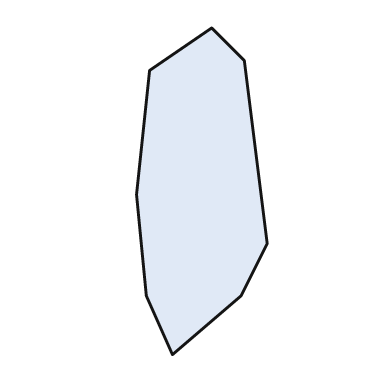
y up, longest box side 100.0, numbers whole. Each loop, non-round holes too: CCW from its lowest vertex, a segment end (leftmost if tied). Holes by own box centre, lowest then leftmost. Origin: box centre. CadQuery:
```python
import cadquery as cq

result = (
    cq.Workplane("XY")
    .moveTo(-9.0, -50.0)
    .lineTo(12.0, -32.0)
    .lineTo(20.0, -16.0)
    .lineTo(13.0, 40.0)
    .lineTo(3.0, 50.0)
    .lineTo(-16.0, 37.0)
    .lineTo(-20.0, -1.0)
    .lineTo(-17.0, -32.0)
    .close()
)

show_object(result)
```